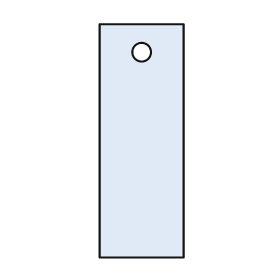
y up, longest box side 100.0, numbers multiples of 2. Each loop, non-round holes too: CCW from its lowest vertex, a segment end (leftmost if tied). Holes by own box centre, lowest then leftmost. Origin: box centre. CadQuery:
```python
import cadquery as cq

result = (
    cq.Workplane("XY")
    .moveTo(-18.0, -50.0)
    .lineTo(18.0, -50.0)
    .lineTo(18.0, 50.0)
    .lineTo(-18.0, 50.0)
    .close()
    .moveTo(0.0, 38.0)
    .circle(4.0)
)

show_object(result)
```